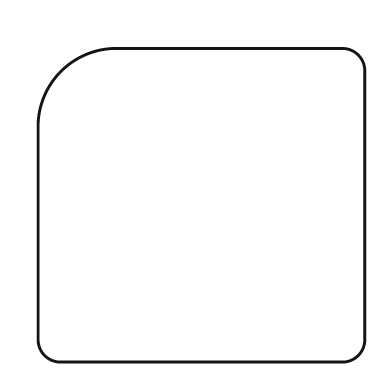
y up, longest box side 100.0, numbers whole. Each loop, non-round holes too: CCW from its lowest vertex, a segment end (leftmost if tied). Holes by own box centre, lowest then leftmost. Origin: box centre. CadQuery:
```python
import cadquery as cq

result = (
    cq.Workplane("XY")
    .moveTo(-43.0, -48.0)
    .lineTo(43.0, -48.0)
    .threePointArc((48.0, -46.0), (50.0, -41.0))
    .lineTo(50.0, 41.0)
    .threePointArc((48.0, 46.0), (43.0, 48.0))
    .lineTo(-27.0, 48.0)
    .threePointArc((-43.0, 41.0), (-50.0, 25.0))
    .lineTo(-50.0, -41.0)
    .threePointArc((-48.0, -46.0), (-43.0, -48.0))
    .close()
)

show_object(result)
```